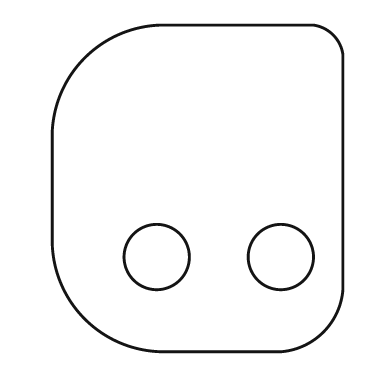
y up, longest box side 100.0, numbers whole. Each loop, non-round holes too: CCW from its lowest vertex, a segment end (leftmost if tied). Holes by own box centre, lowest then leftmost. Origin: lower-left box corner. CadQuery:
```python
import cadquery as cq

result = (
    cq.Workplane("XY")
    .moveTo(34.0, 0.0)
    .lineTo(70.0, 0.0)
    .threePointArc((83.0, 6.0), (89.0, 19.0))
    .lineTo(89.0, 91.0)
    .threePointArc((86.0, 97.0), (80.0, 100.0))
    .lineTo(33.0, 100.0)
    .threePointArc((10.0, 90.0), (0.0, 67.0))
    .lineTo(0.0, 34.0)
    .threePointArc((10.0, 10.0), (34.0, 0.0))
    .close()
    .moveTo(32.0, 29.0)
    .circle(10.0)
    .moveTo(70.0, 29.0)
    .circle(10.0)
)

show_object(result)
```